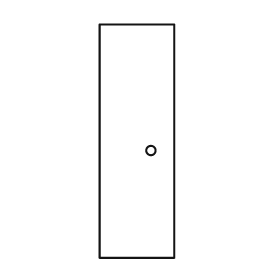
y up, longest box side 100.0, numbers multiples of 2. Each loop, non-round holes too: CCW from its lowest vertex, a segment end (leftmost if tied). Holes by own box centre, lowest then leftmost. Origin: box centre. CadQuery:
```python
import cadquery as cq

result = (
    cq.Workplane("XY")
    .moveTo(-16.0, -50.0)
    .lineTo(16.0, -50.0)
    .lineTo(16.0, 50.0)
    .lineTo(-16.0, 50.0)
    .close()
    .moveTo(6.0, -4.0)
    .circle(2.0)
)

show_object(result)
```